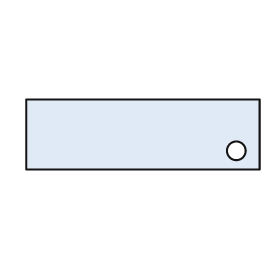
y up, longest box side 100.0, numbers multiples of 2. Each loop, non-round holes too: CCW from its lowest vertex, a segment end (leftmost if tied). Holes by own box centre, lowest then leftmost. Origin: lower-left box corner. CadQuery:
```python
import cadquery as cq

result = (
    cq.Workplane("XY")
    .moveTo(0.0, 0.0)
    .lineTo(100.0, 0.0)
    .lineTo(100.0, 30.0)
    .lineTo(0.0, 30.0)
    .close()
    .moveTo(90.0, 8.0)
    .circle(4.0)
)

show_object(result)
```